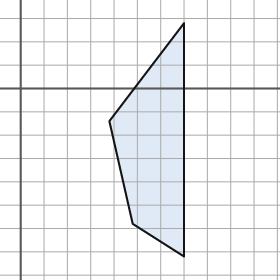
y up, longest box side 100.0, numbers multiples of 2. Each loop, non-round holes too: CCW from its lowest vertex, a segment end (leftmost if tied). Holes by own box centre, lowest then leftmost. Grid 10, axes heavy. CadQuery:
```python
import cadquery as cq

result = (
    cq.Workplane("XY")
    .moveTo(70.0, -72.0)
    .lineTo(70.0, 28.0)
    .lineTo(38.0, -14.0)
    .lineTo(48.0, -58.0)
    .close()
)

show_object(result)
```